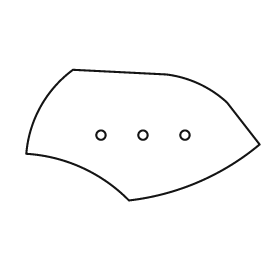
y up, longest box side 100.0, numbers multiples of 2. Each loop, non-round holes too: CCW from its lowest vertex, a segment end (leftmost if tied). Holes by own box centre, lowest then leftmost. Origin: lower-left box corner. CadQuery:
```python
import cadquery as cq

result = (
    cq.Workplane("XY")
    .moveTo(44.0, 0.0)
    .threePointArc((74.0, 8.0), (100.0, 24.0))
    .lineTo(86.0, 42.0)
    .threePointArc((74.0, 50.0), (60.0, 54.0))
    .lineTo(20.0, 56.0)
    .threePointArc((6.0, 40.0), (0.0, 20.0))
    .threePointArc((24.0, 14.0), (44.0, 0.0))
    .close()
    .moveTo(32.0, 28.0)
    .circle(2.0)
    .moveTo(50.0, 28.0)
    .circle(2.0)
    .moveTo(68.0, 28.0)
    .circle(2.0)
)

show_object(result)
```